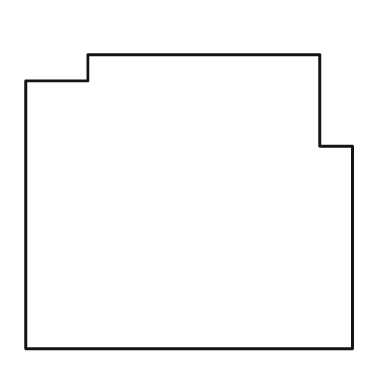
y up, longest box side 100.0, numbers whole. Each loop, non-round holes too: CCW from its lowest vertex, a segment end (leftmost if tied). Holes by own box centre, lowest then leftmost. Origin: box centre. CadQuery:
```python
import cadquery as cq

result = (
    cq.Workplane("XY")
    .moveTo(-50.0, -45.0)
    .lineTo(50.0, -45.0)
    .lineTo(50.0, 17.0)
    .lineTo(40.0, 17.0)
    .lineTo(40.0, 45.0)
    .lineTo(-31.0, 45.0)
    .lineTo(-31.0, 37.0)
    .lineTo(-50.0, 37.0)
    .close()
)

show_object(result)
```